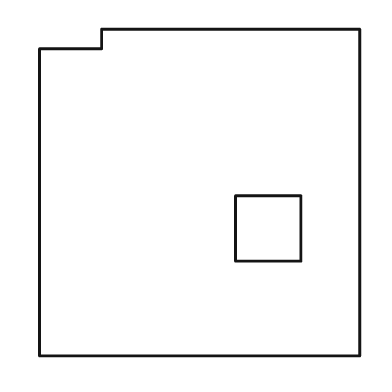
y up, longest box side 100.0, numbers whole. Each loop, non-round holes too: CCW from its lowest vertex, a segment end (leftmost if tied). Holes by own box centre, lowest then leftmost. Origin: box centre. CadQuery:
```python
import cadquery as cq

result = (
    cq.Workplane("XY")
    .moveTo(-49.0, -50.0)
    .lineTo(49.0, -50.0)
    .lineTo(49.0, 50.0)
    .lineTo(-30.0, 50.0)
    .lineTo(-30.0, 44.0)
    .lineTo(-49.0, 44.0)
    .close()
    .moveTo(11.0, -21.0)
    .lineTo(31.0, -21.0)
    .lineTo(31.0, -1.0)
    .lineTo(11.0, -1.0)
    .close()
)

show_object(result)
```